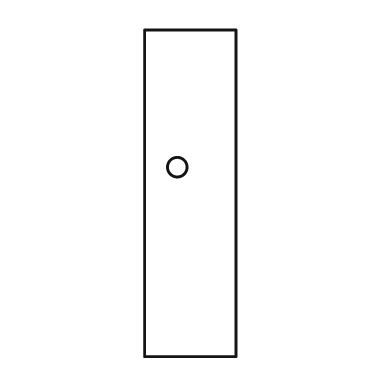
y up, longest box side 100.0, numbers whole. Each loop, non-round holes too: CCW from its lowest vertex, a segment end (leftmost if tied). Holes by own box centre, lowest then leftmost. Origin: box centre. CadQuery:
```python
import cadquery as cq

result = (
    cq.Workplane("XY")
    .moveTo(-14.0, -50.0)
    .lineTo(14.0, -50.0)
    .lineTo(14.0, 50.0)
    .lineTo(-14.0, 50.0)
    .close()
    .moveTo(-4.0, 8.0)
    .circle(3.0)
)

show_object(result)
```